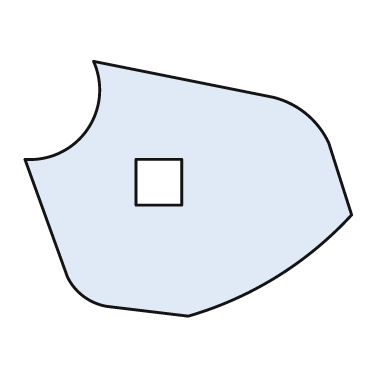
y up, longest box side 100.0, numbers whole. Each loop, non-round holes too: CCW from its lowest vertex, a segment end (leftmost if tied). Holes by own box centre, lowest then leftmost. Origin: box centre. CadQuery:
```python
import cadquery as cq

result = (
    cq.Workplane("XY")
    .moveTo(0.0, -39.0)
    .threePointArc((27.0, -27.0), (50.0, -8.0))
    .lineTo(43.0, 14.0)
    .threePointArc((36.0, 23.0), (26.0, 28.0))
    .lineTo(-29.0, 39.0)
    .threePointArc((-31.0, 18.0), (-50.0, 9.0))
    .lineTo(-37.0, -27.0)
    .threePointArc((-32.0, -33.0), (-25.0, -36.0))
    .close()
    .moveTo(-16.0, -5.0)
    .lineTo(-2.0, -5.0)
    .lineTo(-2.0, 9.0)
    .lineTo(-16.0, 9.0)
    .close()
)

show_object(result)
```